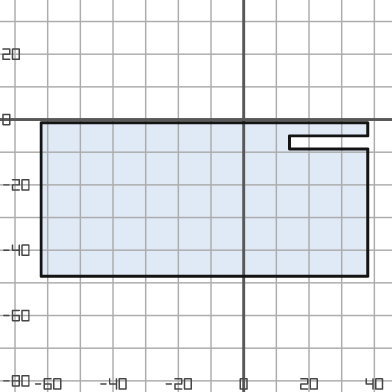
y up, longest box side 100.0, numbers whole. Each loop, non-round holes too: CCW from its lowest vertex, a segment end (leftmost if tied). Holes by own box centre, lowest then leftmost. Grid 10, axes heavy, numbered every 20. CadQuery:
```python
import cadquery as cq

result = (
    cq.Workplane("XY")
    .moveTo(-62.0, -48.0)
    .lineTo(38.0, -48.0)
    .lineTo(38.0, -9.0)
    .lineTo(14.0, -9.0)
    .lineTo(14.0, -5.0)
    .lineTo(38.0, -5.0)
    .lineTo(38.0, -1.0)
    .lineTo(-62.0, -1.0)
    .close()
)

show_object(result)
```